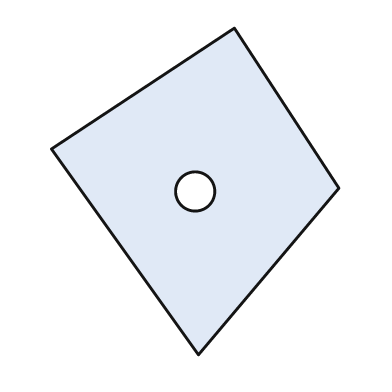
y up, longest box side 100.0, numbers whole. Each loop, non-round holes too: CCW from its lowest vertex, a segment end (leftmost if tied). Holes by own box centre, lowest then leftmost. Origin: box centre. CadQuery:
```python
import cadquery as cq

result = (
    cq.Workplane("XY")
    .moveTo(1.0, -50.0)
    .lineTo(44.0, 1.0)
    .lineTo(12.0, 50.0)
    .lineTo(-44.0, 13.0)
    .close()
    .moveTo(0.0, 0.0)
    .circle(6.0)
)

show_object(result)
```